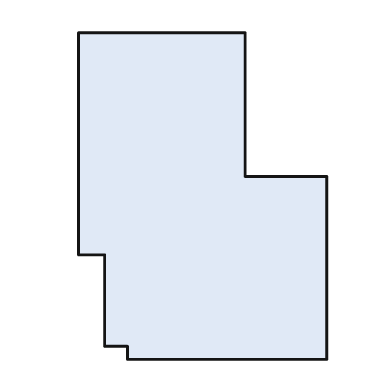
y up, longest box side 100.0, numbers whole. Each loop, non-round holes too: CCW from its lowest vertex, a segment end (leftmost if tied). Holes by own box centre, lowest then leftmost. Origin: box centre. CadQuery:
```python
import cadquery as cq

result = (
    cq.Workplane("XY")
    .moveTo(-23.0, -50.0)
    .lineTo(38.0, -50.0)
    .lineTo(38.0, 6.0)
    .lineTo(13.0, 6.0)
    .lineTo(13.0, 50.0)
    .lineTo(-38.0, 50.0)
    .lineTo(-38.0, -18.0)
    .lineTo(-30.0, -18.0)
    .lineTo(-30.0, -46.0)
    .lineTo(-23.0, -46.0)
    .close()
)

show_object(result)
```